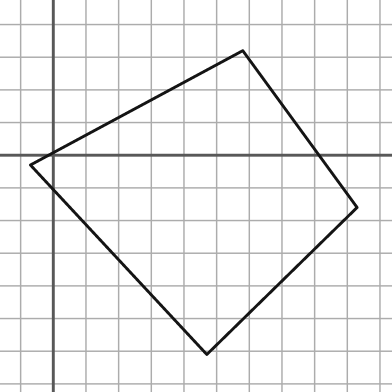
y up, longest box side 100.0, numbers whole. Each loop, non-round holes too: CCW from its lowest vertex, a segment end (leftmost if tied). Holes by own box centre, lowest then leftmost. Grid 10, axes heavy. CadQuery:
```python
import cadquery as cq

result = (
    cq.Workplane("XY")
    .moveTo(47.0, -61.0)
    .lineTo(93.0, -16.0)
    .lineTo(58.0, 32.0)
    .lineTo(-7.0, -3.0)
    .close()
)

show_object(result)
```